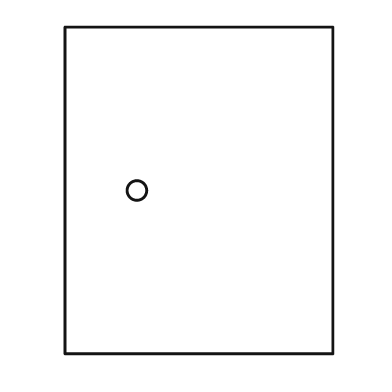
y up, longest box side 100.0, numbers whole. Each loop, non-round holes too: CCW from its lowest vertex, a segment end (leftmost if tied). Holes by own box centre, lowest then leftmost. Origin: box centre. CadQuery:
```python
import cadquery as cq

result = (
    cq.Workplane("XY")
    .moveTo(-41.0, -50.0)
    .lineTo(41.0, -50.0)
    .lineTo(41.0, 50.0)
    .lineTo(-41.0, 50.0)
    .close()
    .moveTo(-19.0, 0.0)
    .circle(3.0)
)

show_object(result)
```